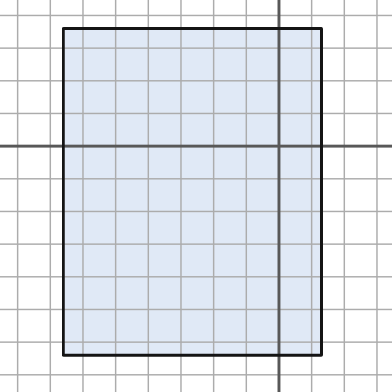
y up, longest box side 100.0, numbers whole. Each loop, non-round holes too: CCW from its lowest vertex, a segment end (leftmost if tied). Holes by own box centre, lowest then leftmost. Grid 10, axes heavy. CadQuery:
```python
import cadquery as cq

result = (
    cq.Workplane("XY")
    .moveTo(-66.0, -64.0)
    .lineTo(13.0, -64.0)
    .lineTo(13.0, 36.0)
    .lineTo(-66.0, 36.0)
    .close()
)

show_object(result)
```